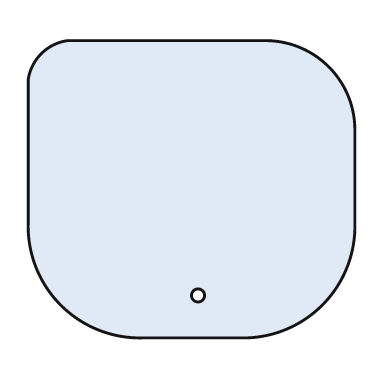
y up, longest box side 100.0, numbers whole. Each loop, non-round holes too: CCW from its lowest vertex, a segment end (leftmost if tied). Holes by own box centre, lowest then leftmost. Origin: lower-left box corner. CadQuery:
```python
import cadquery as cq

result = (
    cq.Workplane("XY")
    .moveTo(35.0, 0.0)
    .lineTo(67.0, 0.0)
    .threePointArc((90.0, 10.0), (100.0, 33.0))
    .lineTo(100.0, 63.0)
    .threePointArc((92.0, 83.0), (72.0, 91.0))
    .lineTo(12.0, 91.0)
    .threePointArc((4.0, 87.0), (0.0, 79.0))
    .lineTo(0.0, 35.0)
    .threePointArc((10.0, 10.0), (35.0, 0.0))
    .close()
    .moveTo(52.0, 13.0)
    .circle(2.0)
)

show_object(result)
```